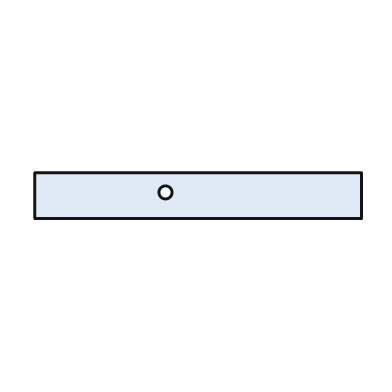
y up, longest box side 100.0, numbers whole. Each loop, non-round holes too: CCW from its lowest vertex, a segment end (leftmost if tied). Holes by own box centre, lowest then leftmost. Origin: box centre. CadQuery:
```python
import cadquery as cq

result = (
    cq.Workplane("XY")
    .moveTo(-50.0, -7.0)
    .lineTo(50.0, -7.0)
    .lineTo(50.0, 7.0)
    .lineTo(-50.0, 7.0)
    .close()
    .moveTo(-10.0, 1.0)
    .circle(2.0)
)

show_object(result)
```